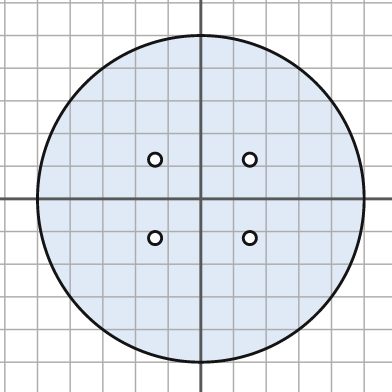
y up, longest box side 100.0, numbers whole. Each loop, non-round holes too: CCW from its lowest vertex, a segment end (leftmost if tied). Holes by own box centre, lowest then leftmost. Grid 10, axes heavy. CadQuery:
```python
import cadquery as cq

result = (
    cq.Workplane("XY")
    .moveTo(0.0, 0.0)
    .circle(50.0)
    .moveTo(-14.0, -12.0)
    .circle(2.0)
    .moveTo(15.0, -12.0)
    .circle(2.0)
    .moveTo(-14.0, 12.0)
    .circle(2.0)
    .moveTo(15.0, 12.0)
    .circle(2.0)
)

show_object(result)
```